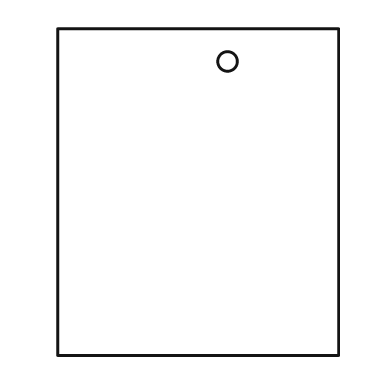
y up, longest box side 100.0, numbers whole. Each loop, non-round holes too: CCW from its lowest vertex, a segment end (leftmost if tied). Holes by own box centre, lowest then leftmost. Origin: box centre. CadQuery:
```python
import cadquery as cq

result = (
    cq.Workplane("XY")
    .moveTo(-43.0, -50.0)
    .lineTo(43.0, -50.0)
    .lineTo(43.0, 50.0)
    .lineTo(-43.0, 50.0)
    .close()
    .moveTo(9.0, 40.0)
    .circle(3.0)
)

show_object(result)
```